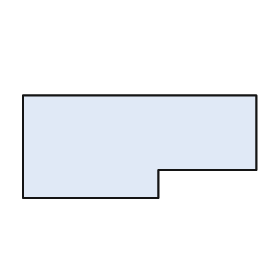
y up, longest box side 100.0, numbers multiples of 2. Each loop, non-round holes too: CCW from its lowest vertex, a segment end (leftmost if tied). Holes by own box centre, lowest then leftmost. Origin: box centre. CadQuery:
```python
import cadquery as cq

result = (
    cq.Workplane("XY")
    .moveTo(-50.0, -22.0)
    .lineTo(8.0, -22.0)
    .lineTo(8.0, -10.0)
    .lineTo(50.0, -10.0)
    .lineTo(50.0, 22.0)
    .lineTo(-50.0, 22.0)
    .close()
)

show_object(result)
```